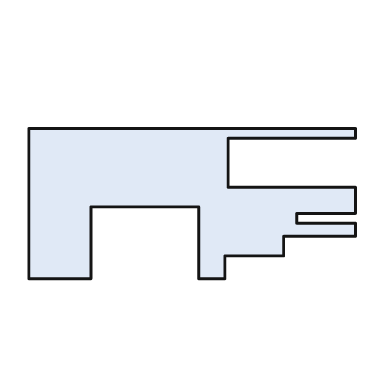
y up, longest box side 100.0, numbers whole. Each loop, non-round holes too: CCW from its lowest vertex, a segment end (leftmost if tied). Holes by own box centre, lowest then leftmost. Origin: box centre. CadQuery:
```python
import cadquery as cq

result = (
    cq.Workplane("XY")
    .moveTo(-50.0, -23.0)
    .lineTo(-31.0, -23.0)
    .lineTo(-31.0, -1.0)
    .lineTo(2.0, -1.0)
    .lineTo(2.0, -23.0)
    .lineTo(10.0, -23.0)
    .lineTo(10.0, -16.0)
    .lineTo(28.0, -16.0)
    .lineTo(28.0, -10.0)
    .lineTo(50.0, -10.0)
    .lineTo(50.0, -6.0)
    .lineTo(32.0, -6.0)
    .lineTo(32.0, -3.0)
    .lineTo(50.0, -3.0)
    .lineTo(50.0, 5.0)
    .lineTo(11.0, 5.0)
    .lineTo(11.0, 20.0)
    .lineTo(50.0, 20.0)
    .lineTo(50.0, 23.0)
    .lineTo(-50.0, 23.0)
    .close()
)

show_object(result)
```